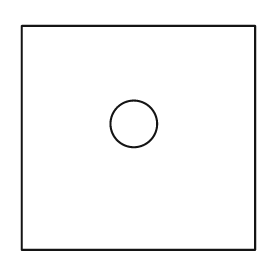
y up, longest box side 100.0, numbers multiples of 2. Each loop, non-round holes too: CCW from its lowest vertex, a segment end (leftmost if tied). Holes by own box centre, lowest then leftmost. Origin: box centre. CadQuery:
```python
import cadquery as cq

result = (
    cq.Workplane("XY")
    .moveTo(-50.0, -48.0)
    .lineTo(50.0, -48.0)
    .lineTo(50.0, 48.0)
    .lineTo(-50.0, 48.0)
    .close()
    .moveTo(-2.0, 6.0)
    .circle(10.0)
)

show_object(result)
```